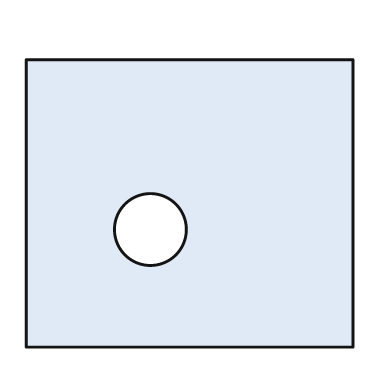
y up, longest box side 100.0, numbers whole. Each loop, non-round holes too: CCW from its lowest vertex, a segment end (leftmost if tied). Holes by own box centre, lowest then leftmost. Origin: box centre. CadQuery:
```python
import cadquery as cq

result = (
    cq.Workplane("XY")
    .moveTo(-50.0, -44.0)
    .lineTo(50.0, -44.0)
    .lineTo(50.0, 44.0)
    .lineTo(-50.0, 44.0)
    .close()
    .moveTo(-12.0, -8.0)
    .circle(11.0)
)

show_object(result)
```